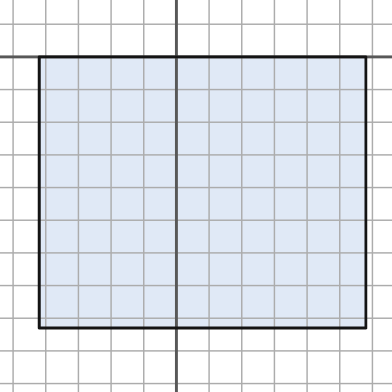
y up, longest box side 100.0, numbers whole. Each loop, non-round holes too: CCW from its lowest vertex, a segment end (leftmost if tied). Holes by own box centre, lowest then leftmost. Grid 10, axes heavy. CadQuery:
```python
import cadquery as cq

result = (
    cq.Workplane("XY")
    .moveTo(-42.0, -83.0)
    .lineTo(58.0, -83.0)
    .lineTo(58.0, 0.0)
    .lineTo(-42.0, 0.0)
    .close()
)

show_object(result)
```